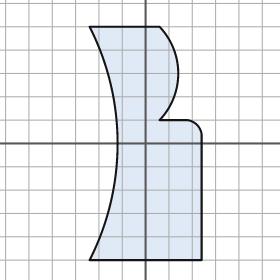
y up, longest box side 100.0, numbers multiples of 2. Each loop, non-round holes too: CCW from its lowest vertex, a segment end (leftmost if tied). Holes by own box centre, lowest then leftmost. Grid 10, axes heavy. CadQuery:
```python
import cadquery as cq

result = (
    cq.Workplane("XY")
    .moveTo(-24.0, -50.0)
    .lineTo(24.0, -50.0)
    .lineTo(24.0, 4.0)
    .threePointArc((22.0, 8.0), (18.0, 10.0))
    .lineTo(6.0, 10.0)
    .threePointArc((14.0, 30.0), (6.0, 50.0))
    .lineTo(-24.0, 50.0)
    .threePointArc((-12.0, 0.0), (-24.0, -50.0))
    .close()
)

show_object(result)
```